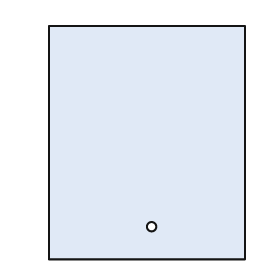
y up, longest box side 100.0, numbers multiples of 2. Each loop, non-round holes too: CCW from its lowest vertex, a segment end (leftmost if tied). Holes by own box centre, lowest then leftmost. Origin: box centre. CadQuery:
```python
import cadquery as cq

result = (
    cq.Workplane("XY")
    .moveTo(-42.0, -50.0)
    .lineTo(42.0, -50.0)
    .lineTo(42.0, 50.0)
    .lineTo(-42.0, 50.0)
    .close()
    .moveTo(2.0, -36.0)
    .circle(2.0)
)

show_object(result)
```